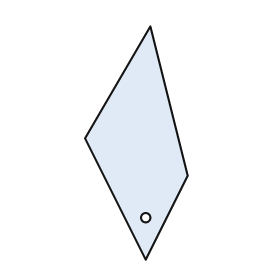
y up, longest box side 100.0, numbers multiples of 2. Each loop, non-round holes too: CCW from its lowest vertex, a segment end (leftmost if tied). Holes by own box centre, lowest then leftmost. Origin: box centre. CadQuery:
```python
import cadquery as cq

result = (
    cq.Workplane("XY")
    .moveTo(4.0, -50.0)
    .lineTo(22.0, -14.0)
    .lineTo(6.0, 50.0)
    .lineTo(-22.0, 2.0)
    .close()
    .moveTo(4.0, -32.0)
    .circle(2.0)
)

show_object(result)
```